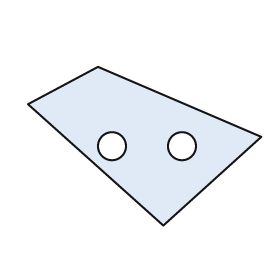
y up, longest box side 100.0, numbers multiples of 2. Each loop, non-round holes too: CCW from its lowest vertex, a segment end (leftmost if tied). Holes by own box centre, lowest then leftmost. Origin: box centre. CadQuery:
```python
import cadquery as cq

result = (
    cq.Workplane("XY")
    .moveTo(8.0, -34.0)
    .lineTo(50.0, 4.0)
    .lineTo(-20.0, 34.0)
    .lineTo(-50.0, 18.0)
    .close()
    .moveTo(-14.0, 0.0)
    .circle(6.0)
    .moveTo(16.0, 0.0)
    .circle(6.0)
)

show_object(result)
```